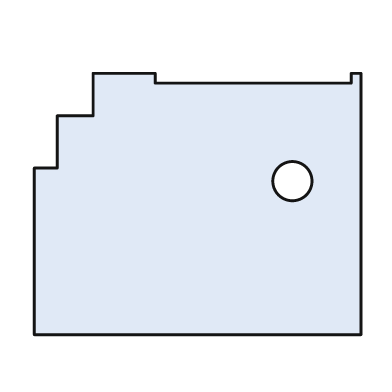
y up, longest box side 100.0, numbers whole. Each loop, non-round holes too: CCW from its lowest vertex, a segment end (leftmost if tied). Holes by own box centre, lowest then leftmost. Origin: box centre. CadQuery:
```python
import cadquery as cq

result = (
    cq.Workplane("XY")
    .moveTo(-50.0, -40.0)
    .lineTo(50.0, -40.0)
    .lineTo(50.0, 40.0)
    .lineTo(47.0, 40.0)
    .lineTo(47.0, 37.0)
    .lineTo(-13.0, 37.0)
    .lineTo(-13.0, 40.0)
    .lineTo(-32.0, 40.0)
    .lineTo(-32.0, 27.0)
    .lineTo(-43.0, 27.0)
    .lineTo(-43.0, 11.0)
    .lineTo(-50.0, 11.0)
    .close()
    .moveTo(29.0, 7.0)
    .circle(6.0)
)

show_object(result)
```